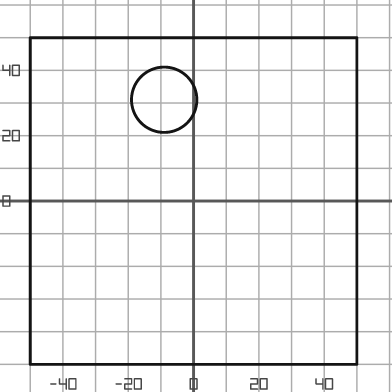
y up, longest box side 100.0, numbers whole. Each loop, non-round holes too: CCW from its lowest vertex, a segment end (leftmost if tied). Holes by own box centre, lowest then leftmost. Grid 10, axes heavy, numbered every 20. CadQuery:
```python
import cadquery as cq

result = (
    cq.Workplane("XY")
    .moveTo(-50.0, -50.0)
    .lineTo(50.0, -50.0)
    .lineTo(50.0, 50.0)
    .lineTo(-50.0, 50.0)
    .close()
    .moveTo(-9.0, 31.0)
    .circle(10.0)
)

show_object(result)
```